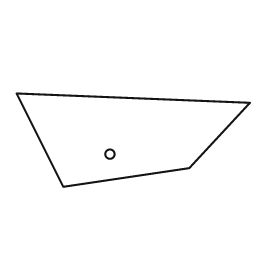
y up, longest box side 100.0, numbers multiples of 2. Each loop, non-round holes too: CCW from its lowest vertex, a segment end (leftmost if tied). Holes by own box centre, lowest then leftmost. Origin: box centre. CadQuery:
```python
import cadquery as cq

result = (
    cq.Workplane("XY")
    .moveTo(-30.0, -20.0)
    .lineTo(24.0, -12.0)
    .lineTo(50.0, 16.0)
    .lineTo(-50.0, 20.0)
    .close()
    .moveTo(-10.0, -6.0)
    .circle(2.0)
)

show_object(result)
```